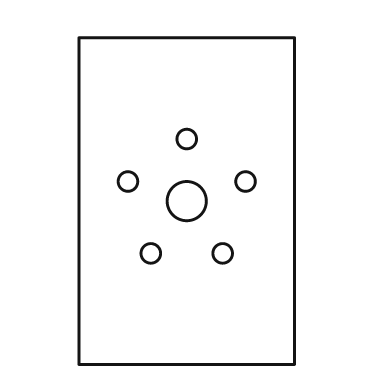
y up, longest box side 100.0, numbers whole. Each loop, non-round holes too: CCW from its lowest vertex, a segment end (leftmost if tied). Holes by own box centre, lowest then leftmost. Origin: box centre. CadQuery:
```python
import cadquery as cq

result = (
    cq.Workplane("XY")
    .moveTo(-33.0, -50.0)
    .lineTo(33.0, -50.0)
    .lineTo(33.0, 50.0)
    .lineTo(-33.0, 50.0)
    .close()
    .moveTo(-11.0, -16.0)
    .circle(3.0)
    .moveTo(11.0, -16.0)
    .circle(3.0)
    .moveTo(0.0, 0.0)
    .circle(6.0)
    .moveTo(-18.0, 6.0)
    .circle(3.0)
    .moveTo(18.0, 6.0)
    .circle(3.0)
    .moveTo(0.0, 19.0)
    .circle(3.0)
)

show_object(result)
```